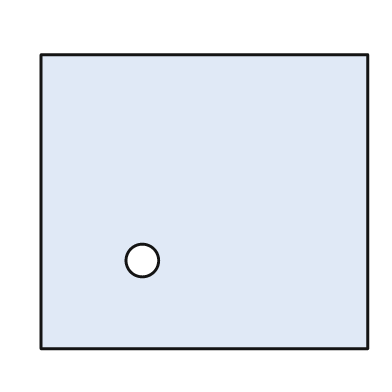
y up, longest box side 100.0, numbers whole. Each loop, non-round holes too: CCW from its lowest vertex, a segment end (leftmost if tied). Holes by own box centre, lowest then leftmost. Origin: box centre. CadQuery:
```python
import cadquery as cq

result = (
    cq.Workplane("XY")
    .moveTo(-50.0, -45.0)
    .lineTo(50.0, -45.0)
    .lineTo(50.0, 45.0)
    .lineTo(-50.0, 45.0)
    .close()
    .moveTo(-19.0, -18.0)
    .circle(5.0)
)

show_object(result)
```